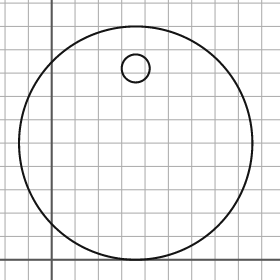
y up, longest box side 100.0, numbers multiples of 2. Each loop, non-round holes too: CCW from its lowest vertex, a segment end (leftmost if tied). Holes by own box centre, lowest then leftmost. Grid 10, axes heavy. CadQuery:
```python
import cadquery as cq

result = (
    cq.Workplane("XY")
    .moveTo(36.0, 50.0)
    .circle(50.0)
    .moveTo(36.0, 82.0)
    .circle(6.0)
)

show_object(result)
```